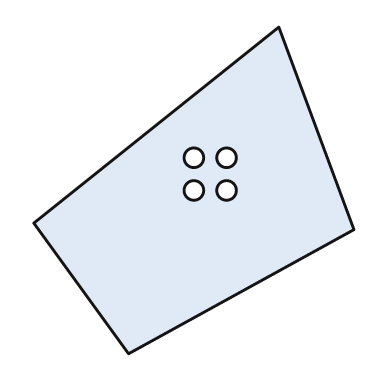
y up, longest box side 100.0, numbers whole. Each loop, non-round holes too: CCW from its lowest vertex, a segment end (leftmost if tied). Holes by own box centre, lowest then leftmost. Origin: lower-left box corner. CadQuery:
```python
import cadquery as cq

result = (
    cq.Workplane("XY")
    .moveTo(29.0, 0.0)
    .lineTo(98.0, 38.0)
    .lineTo(75.0, 100.0)
    .lineTo(0.0, 40.0)
    .close()
    .moveTo(49.0, 50.0)
    .circle(3.0)
    .moveTo(59.0, 50.0)
    .circle(3.0)
    .moveTo(49.0, 60.0)
    .circle(3.0)
    .moveTo(59.0, 60.0)
    .circle(3.0)
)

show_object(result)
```